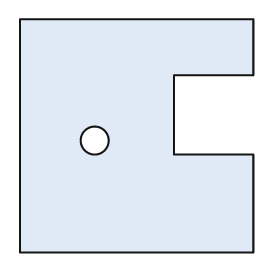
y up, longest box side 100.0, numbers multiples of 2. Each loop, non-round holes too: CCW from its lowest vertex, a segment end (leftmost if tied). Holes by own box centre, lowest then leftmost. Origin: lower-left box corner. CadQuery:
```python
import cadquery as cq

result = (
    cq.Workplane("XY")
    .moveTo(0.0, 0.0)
    .lineTo(100.0, 0.0)
    .lineTo(100.0, 42.0)
    .lineTo(66.0, 42.0)
    .lineTo(66.0, 76.0)
    .lineTo(100.0, 76.0)
    .lineTo(100.0, 100.0)
    .lineTo(0.0, 100.0)
    .close()
    .moveTo(32.0, 48.0)
    .circle(6.0)
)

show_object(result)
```